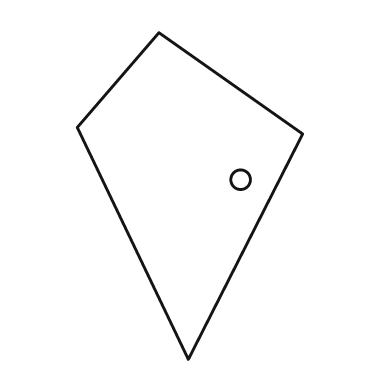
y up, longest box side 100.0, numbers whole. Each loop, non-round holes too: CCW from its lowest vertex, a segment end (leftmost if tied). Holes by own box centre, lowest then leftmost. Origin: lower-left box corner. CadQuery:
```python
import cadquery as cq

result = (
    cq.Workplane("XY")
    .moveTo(34.0, 0.0)
    .lineTo(69.0, 69.0)
    .lineTo(25.0, 100.0)
    .lineTo(0.0, 71.0)
    .close()
    .moveTo(50.0, 55.0)
    .circle(3.0)
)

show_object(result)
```